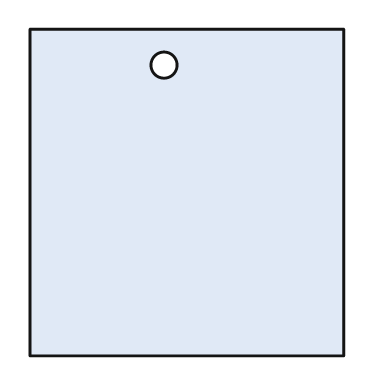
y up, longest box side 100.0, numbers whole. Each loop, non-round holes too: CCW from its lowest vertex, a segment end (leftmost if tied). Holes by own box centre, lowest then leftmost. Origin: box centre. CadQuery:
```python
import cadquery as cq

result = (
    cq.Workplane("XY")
    .moveTo(-48.0, -50.0)
    .lineTo(48.0, -50.0)
    .lineTo(48.0, 50.0)
    .lineTo(-48.0, 50.0)
    .close()
    .moveTo(-7.0, 39.0)
    .circle(4.0)
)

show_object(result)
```